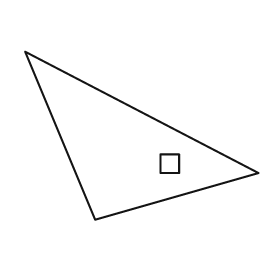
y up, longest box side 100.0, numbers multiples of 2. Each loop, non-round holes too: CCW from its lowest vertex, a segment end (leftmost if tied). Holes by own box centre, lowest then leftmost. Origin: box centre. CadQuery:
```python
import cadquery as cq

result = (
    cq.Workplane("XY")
    .moveTo(-20.0, -36.0)
    .lineTo(50.0, -16.0)
    .lineTo(-50.0, 36.0)
    .close()
    .moveTo(8.0, -16.0)
    .lineTo(16.0, -16.0)
    .lineTo(16.0, -8.0)
    .lineTo(8.0, -8.0)
    .close()
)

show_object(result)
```